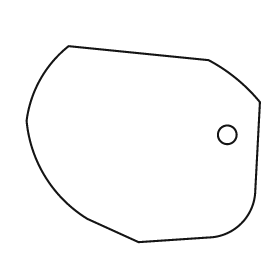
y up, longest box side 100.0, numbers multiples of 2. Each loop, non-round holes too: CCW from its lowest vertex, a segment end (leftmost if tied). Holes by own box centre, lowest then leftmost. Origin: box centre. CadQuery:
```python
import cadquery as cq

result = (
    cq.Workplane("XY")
    .moveTo(-2.0, -42.0)
    .lineTo(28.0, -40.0)
    .threePointArc((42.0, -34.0), (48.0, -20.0))
    .lineTo(50.0, 18.0)
    .threePointArc((40.0, 28.0), (28.0, 36.0))
    .lineTo(-32.0, 42.0)
    .threePointArc((-44.0, 28.0), (-50.0, 10.0))
    .threePointArc((-42.0, -14.0), (-24.0, -32.0))
    .close()
    .moveTo(36.0, 4.0)
    .circle(4.0)
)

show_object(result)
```